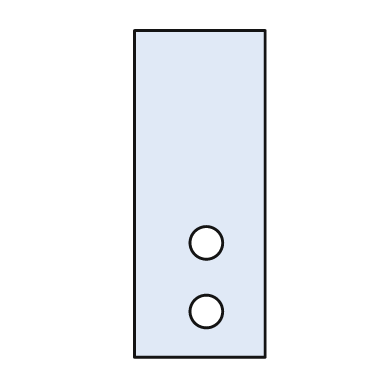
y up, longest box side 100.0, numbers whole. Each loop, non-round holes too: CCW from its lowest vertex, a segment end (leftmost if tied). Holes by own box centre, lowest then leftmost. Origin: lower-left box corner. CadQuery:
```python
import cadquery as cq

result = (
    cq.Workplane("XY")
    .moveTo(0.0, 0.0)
    .lineTo(40.0, 0.0)
    .lineTo(40.0, 100.0)
    .lineTo(0.0, 100.0)
    .close()
    .moveTo(22.0, 14.0)
    .circle(5.0)
    .moveTo(22.0, 35.0)
    .circle(5.0)
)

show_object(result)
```